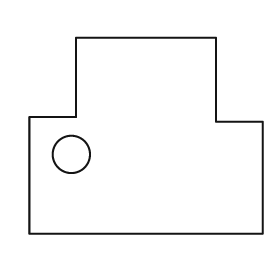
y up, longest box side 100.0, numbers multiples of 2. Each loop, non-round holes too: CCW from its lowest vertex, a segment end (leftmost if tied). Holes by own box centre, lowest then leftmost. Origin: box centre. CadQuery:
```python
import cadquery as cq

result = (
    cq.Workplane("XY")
    .moveTo(-50.0, -42.0)
    .lineTo(50.0, -42.0)
    .lineTo(50.0, 6.0)
    .lineTo(30.0, 6.0)
    .lineTo(30.0, 42.0)
    .lineTo(-30.0, 42.0)
    .lineTo(-30.0, 8.0)
    .lineTo(-50.0, 8.0)
    .close()
    .moveTo(-32.0, -8.0)
    .circle(8.0)
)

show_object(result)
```